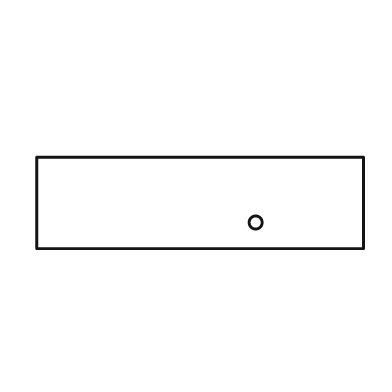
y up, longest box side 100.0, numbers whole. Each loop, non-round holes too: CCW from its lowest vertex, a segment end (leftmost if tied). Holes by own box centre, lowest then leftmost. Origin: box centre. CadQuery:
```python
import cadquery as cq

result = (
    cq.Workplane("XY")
    .moveTo(-50.0, -14.0)
    .lineTo(50.0, -14.0)
    .lineTo(50.0, 14.0)
    .lineTo(-50.0, 14.0)
    .close()
    .moveTo(17.0, -6.0)
    .circle(2.0)
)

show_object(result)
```